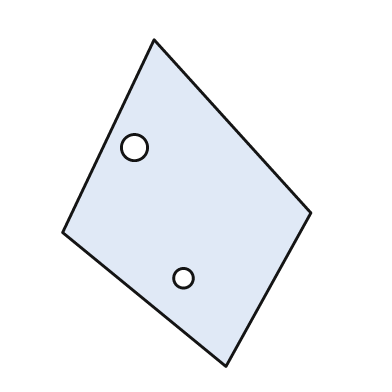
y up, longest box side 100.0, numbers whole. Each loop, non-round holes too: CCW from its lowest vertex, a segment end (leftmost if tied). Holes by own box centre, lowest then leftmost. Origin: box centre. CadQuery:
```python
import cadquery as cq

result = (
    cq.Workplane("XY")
    .moveTo(12.0, -50.0)
    .lineTo(38.0, -3.0)
    .lineTo(-10.0, 50.0)
    .lineTo(-38.0, -9.0)
    .close()
    .moveTo(-1.0, -23.0)
    .circle(3.0)
    .moveTo(-16.0, 17.0)
    .circle(4.0)
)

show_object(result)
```